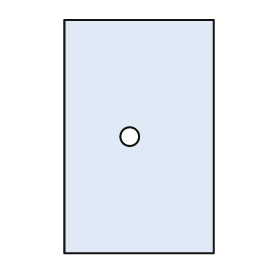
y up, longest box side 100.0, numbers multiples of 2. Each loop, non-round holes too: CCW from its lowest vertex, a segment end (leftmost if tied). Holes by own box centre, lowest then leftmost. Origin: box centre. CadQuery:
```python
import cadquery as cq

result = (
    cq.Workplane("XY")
    .moveTo(-32.0, -50.0)
    .lineTo(32.0, -50.0)
    .lineTo(32.0, 50.0)
    .lineTo(-32.0, 50.0)
    .close()
    .moveTo(-4.0, 0.0)
    .circle(4.0)
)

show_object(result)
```